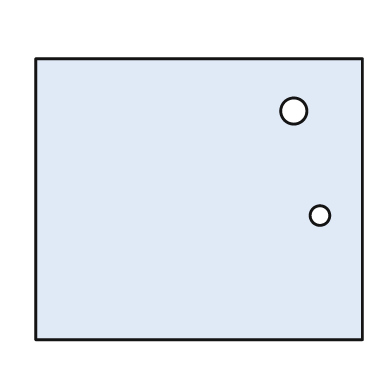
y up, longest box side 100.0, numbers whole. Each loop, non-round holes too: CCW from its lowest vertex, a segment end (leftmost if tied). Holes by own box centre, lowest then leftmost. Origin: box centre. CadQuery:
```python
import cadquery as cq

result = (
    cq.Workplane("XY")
    .moveTo(-50.0, -43.0)
    .lineTo(50.0, -43.0)
    .lineTo(50.0, 43.0)
    .lineTo(-50.0, 43.0)
    .close()
    .moveTo(37.0, -5.0)
    .circle(3.0)
    .moveTo(29.0, 27.0)
    .circle(4.0)
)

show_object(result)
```